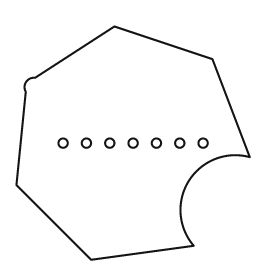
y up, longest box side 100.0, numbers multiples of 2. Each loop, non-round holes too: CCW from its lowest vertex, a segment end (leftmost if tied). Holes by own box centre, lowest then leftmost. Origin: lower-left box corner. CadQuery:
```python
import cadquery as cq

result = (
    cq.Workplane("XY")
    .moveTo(32.0, 0.0)
    .lineTo(76.0, 6.0)
    .threePointArc((74.0, 34.0), (100.0, 44.0))
    .lineTo(84.0, 86.0)
    .lineTo(42.0, 100.0)
    .lineTo(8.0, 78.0)
    .threePointArc((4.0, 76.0), (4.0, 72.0))
    .lineTo(0.0, 32.0)
    .close()
    .moveTo(20.0, 50.0)
    .circle(2.0)
    .moveTo(30.0, 50.0)
    .circle(2.0)
    .moveTo(40.0, 50.0)
    .circle(2.0)
    .moveTo(50.0, 50.0)
    .circle(2.0)
    .moveTo(60.0, 50.0)
    .circle(2.0)
    .moveTo(70.0, 50.0)
    .circle(2.0)
    .moveTo(80.0, 50.0)
    .circle(2.0)
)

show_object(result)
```